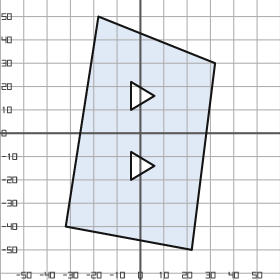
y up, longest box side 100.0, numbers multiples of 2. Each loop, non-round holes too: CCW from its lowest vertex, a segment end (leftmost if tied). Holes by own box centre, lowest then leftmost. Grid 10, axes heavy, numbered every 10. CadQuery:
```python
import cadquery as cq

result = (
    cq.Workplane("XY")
    .moveTo(22.0, -50.0)
    .lineTo(32.0, 30.0)
    .lineTo(-18.0, 50.0)
    .lineTo(-32.0, -40.0)
    .close()
    .moveTo(-4.0, -20.0)
    .lineTo(6.0, -14.0)
    .lineTo(-4.0, -8.0)
    .close()
    .moveTo(-4.0, 10.0)
    .lineTo(6.0, 16.0)
    .lineTo(-4.0, 22.0)
    .close()
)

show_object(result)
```